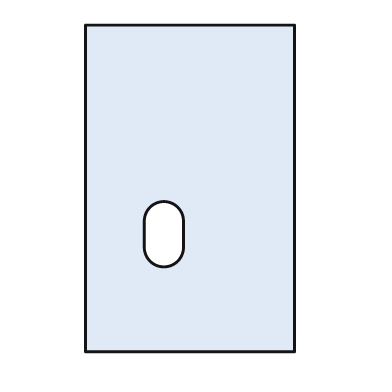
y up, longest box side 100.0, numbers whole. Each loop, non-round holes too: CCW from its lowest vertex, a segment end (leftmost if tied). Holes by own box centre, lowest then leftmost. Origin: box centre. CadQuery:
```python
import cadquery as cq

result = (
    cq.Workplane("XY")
    .moveTo(-32.0, -50.0)
    .lineTo(32.0, -50.0)
    .lineTo(32.0, 50.0)
    .lineTo(-32.0, 50.0)
    .close()
    .moveTo(-14.0, -18.0)
    .threePointArc((-8.0, -24.0), (-2.0, -18.0))
    .lineTo(-2.0, -10.0)
    .threePointArc((-8.0, -4.0), (-14.0, -10.0))
    .close()
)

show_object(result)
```